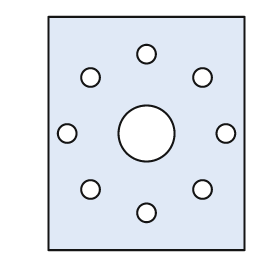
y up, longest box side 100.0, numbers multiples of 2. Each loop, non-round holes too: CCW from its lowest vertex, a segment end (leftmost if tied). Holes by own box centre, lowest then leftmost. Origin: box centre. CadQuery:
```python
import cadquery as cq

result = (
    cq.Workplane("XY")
    .moveTo(-42.0, -50.0)
    .lineTo(42.0, -50.0)
    .lineTo(42.0, 50.0)
    .lineTo(-42.0, 50.0)
    .close()
    .moveTo(0.0, -34.0)
    .circle(4.0)
    .moveTo(-24.0, -24.0)
    .circle(4.0)
    .moveTo(24.0, -24.0)
    .circle(4.0)
    .moveTo(-34.0, 0.0)
    .circle(4.0)
    .moveTo(0.0, 0.0)
    .circle(12.0)
    .moveTo(34.0, 0.0)
    .circle(4.0)
    .moveTo(-24.0, 24.0)
    .circle(4.0)
    .moveTo(24.0, 24.0)
    .circle(4.0)
    .moveTo(0.0, 34.0)
    .circle(4.0)
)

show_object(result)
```